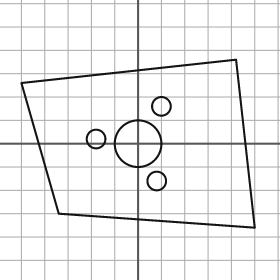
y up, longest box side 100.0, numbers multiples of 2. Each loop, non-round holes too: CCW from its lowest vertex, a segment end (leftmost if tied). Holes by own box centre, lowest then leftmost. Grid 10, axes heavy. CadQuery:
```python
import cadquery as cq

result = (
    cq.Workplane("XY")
    .moveTo(50.0, -36.0)
    .lineTo(42.0, 36.0)
    .lineTo(-50.0, 26.0)
    .lineTo(-34.0, -30.0)
    .close()
    .moveTo(8.0, -16.0)
    .circle(4.0)
    .moveTo(0.0, 0.0)
    .circle(10.0)
    .moveTo(-18.0, 2.0)
    .circle(4.0)
    .moveTo(10.0, 16.0)
    .circle(4.0)
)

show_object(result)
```